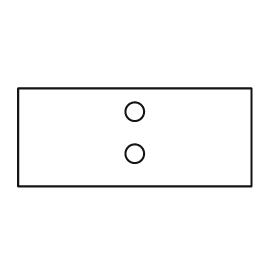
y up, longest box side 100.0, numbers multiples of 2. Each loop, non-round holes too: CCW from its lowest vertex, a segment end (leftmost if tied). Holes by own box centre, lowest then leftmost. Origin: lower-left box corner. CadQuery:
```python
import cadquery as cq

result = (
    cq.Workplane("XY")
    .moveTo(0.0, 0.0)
    .lineTo(100.0, 0.0)
    .lineTo(100.0, 42.0)
    .lineTo(0.0, 42.0)
    .close()
    .moveTo(50.0, 14.0)
    .circle(4.0)
    .moveTo(50.0, 32.0)
    .circle(4.0)
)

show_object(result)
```